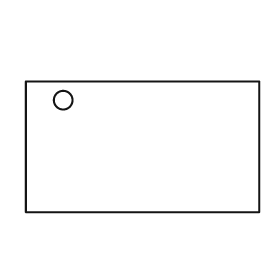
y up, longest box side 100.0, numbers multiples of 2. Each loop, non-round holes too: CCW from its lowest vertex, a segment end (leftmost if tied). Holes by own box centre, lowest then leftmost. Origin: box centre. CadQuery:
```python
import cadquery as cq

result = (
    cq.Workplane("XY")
    .moveTo(-50.0, -28.0)
    .lineTo(50.0, -28.0)
    .lineTo(50.0, 28.0)
    .lineTo(-50.0, 28.0)
    .close()
    .moveTo(-34.0, 20.0)
    .circle(4.0)
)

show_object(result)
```